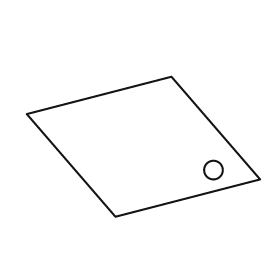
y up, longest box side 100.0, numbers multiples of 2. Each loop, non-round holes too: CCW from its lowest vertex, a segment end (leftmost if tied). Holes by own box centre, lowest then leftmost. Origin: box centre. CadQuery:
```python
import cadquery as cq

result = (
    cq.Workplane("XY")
    .moveTo(-12.0, -30.0)
    .lineTo(50.0, -14.0)
    .lineTo(12.0, 30.0)
    .lineTo(-50.0, 14.0)
    .close()
    .moveTo(30.0, -10.0)
    .circle(4.0)
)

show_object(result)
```